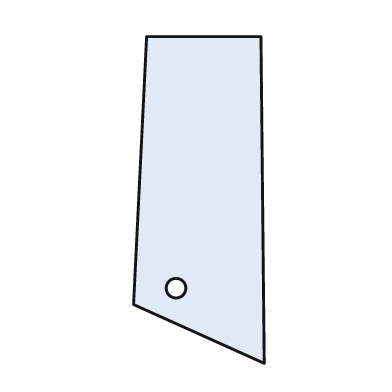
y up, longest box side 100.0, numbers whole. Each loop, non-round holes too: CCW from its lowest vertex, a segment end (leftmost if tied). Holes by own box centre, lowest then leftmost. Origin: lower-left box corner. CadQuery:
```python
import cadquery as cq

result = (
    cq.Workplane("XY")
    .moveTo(40.0, 0.0)
    .lineTo(39.0, 100.0)
    .lineTo(4.0, 100.0)
    .lineTo(0.0, 18.0)
    .close()
    .moveTo(13.0, 23.0)
    .circle(3.0)
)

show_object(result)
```